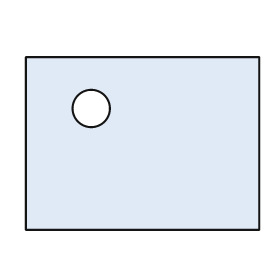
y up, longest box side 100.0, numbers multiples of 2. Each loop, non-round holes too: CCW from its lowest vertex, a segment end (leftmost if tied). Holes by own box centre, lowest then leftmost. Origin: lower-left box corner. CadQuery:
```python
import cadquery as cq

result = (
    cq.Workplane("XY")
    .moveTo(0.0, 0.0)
    .lineTo(100.0, 0.0)
    .lineTo(100.0, 74.0)
    .lineTo(0.0, 74.0)
    .close()
    .moveTo(28.0, 52.0)
    .circle(8.0)
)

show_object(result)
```